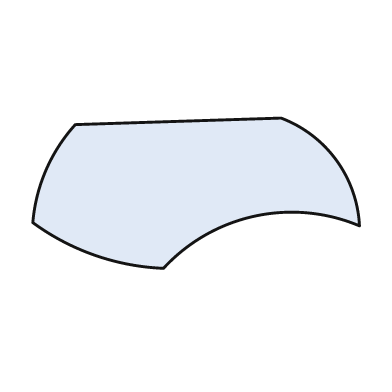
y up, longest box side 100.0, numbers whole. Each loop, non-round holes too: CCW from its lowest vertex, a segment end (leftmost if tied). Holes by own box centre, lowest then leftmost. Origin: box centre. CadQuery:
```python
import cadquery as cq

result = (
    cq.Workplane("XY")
    .moveTo(-10.0, -23.0)
    .threePointArc((18.0, -7.0), (50.0, -10.0))
    .threePointArc((43.0, 10.0), (26.0, 23.0))
    .lineTo(-37.0, 21.0)
    .threePointArc((-46.0, 7.0), (-50.0, -9.0))
    .threePointArc((-31.0, -19.0), (-10.0, -23.0))
    .close()
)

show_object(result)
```